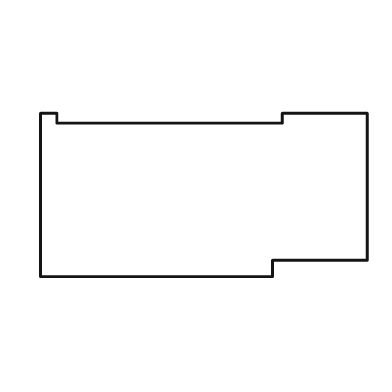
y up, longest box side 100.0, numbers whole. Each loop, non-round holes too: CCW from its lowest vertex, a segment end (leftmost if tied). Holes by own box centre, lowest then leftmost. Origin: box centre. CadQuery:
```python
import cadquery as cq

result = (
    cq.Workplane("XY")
    .moveTo(-50.0, -25.0)
    .lineTo(21.0, -25.0)
    .lineTo(21.0, -20.0)
    .lineTo(50.0, -20.0)
    .lineTo(50.0, 25.0)
    .lineTo(24.0, 25.0)
    .lineTo(24.0, 22.0)
    .lineTo(-45.0, 22.0)
    .lineTo(-45.0, 25.0)
    .lineTo(-50.0, 25.0)
    .close()
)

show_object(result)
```